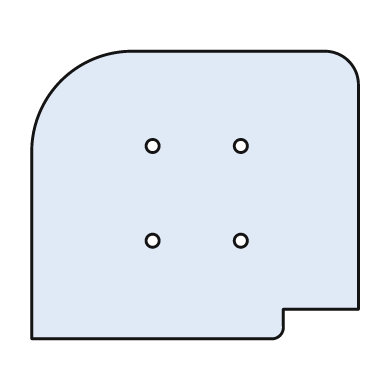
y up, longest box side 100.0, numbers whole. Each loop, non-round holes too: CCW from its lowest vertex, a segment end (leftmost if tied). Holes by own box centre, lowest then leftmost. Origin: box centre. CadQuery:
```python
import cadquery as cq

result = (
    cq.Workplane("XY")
    .moveTo(-50.0, -44.0)
    .lineTo(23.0, -44.0)
    .threePointArc((26.0, -43.0), (27.0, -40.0))
    .lineTo(27.0, -35.0)
    .lineTo(50.0, -35.0)
    .lineTo(50.0, 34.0)
    .threePointArc((47.0, 41.0), (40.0, 44.0))
    .lineTo(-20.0, 44.0)
    .threePointArc((-41.0, 35.0), (-50.0, 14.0))
    .close()
    .moveTo(-13.0, -14.0)
    .circle(2.0)
    .moveTo(14.0, -14.0)
    .circle(2.0)
    .moveTo(-13.0, 15.0)
    .circle(2.0)
    .moveTo(14.0, 15.0)
    .circle(2.0)
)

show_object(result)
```